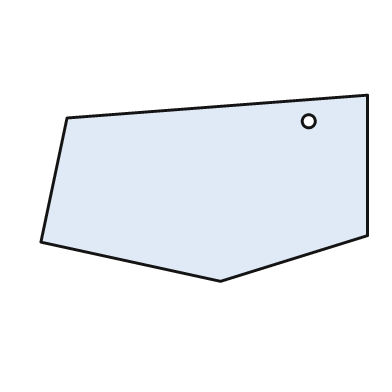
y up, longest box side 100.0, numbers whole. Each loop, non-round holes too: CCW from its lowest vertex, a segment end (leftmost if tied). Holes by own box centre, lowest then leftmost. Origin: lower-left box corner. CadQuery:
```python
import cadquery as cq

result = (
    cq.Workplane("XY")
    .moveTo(55.0, 0.0)
    .lineTo(100.0, 14.0)
    .lineTo(100.0, 57.0)
    .lineTo(8.0, 50.0)
    .lineTo(0.0, 12.0)
    .close()
    .moveTo(82.0, 49.0)
    .circle(2.0)
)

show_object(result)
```